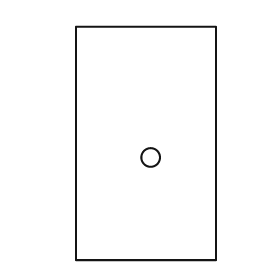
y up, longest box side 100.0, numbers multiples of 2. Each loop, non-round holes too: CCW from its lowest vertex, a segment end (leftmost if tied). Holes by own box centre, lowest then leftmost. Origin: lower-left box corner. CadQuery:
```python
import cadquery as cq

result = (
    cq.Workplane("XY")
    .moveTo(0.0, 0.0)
    .lineTo(60.0, 0.0)
    .lineTo(60.0, 100.0)
    .lineTo(0.0, 100.0)
    .close()
    .moveTo(32.0, 44.0)
    .circle(4.0)
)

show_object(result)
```